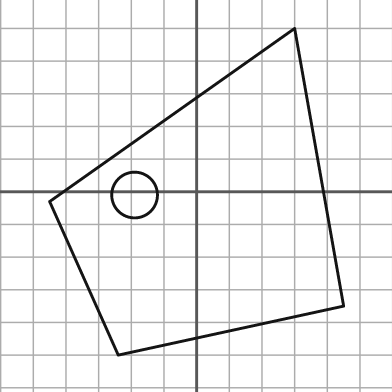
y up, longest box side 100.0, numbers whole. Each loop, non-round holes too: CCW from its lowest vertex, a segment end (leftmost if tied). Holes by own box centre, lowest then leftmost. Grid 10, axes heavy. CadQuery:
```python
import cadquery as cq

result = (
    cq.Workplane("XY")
    .moveTo(-24.0, -50.0)
    .lineTo(45.0, -35.0)
    .lineTo(30.0, 50.0)
    .lineTo(-45.0, -3.0)
    .close()
    .moveTo(-19.0, -1.0)
    .circle(7.0)
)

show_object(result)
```